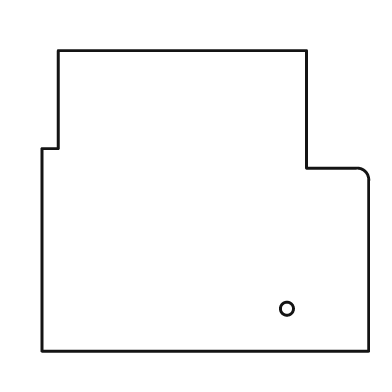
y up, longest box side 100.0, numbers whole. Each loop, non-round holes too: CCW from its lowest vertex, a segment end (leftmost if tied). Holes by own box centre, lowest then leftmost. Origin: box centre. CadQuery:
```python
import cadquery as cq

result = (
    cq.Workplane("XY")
    .moveTo(-50.0, -46.0)
    .lineTo(50.0, -46.0)
    .lineTo(50.0, 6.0)
    .threePointArc((49.0, 9.0), (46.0, 10.0))
    .lineTo(31.0, 10.0)
    .lineTo(31.0, 46.0)
    .lineTo(-45.0, 46.0)
    .lineTo(-45.0, 16.0)
    .lineTo(-50.0, 16.0)
    .close()
    .moveTo(25.0, -33.0)
    .circle(2.0)
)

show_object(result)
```